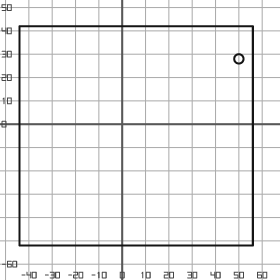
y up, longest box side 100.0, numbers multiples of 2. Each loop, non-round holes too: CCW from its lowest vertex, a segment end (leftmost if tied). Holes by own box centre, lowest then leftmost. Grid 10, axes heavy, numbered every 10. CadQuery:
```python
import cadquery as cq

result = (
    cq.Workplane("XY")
    .moveTo(-44.0, -52.0)
    .lineTo(56.0, -52.0)
    .lineTo(56.0, 42.0)
    .lineTo(-44.0, 42.0)
    .close()
    .moveTo(50.0, 28.0)
    .circle(2.0)
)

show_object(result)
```